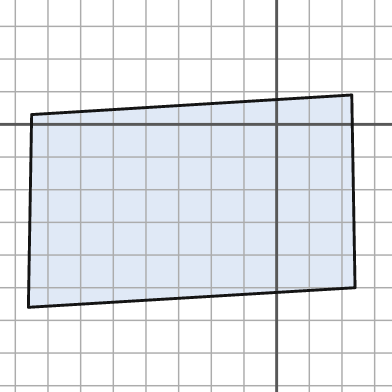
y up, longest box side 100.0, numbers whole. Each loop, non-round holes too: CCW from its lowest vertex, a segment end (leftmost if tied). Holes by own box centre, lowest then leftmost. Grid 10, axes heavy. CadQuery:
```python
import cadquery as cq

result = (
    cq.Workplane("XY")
    .moveTo(-76.0, -56.0)
    .lineTo(24.0, -50.0)
    .lineTo(23.0, 9.0)
    .lineTo(-75.0, 3.0)
    .close()
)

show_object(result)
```